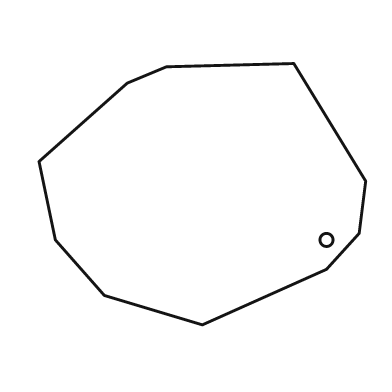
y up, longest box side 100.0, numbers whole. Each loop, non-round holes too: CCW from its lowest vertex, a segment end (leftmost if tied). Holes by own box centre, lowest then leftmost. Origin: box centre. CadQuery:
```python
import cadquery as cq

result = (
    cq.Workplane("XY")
    .moveTo(0.0, -40.0)
    .lineTo(38.0, -23.0)
    .lineTo(48.0, -12.0)
    .lineTo(50.0, 4.0)
    .lineTo(28.0, 40.0)
    .lineTo(-11.0, 39.0)
    .lineTo(-23.0, 34.0)
    .lineTo(-50.0, 10.0)
    .lineTo(-45.0, -14.0)
    .lineTo(-30.0, -31.0)
    .close()
    .moveTo(38.0, -14.0)
    .circle(2.0)
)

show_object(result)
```